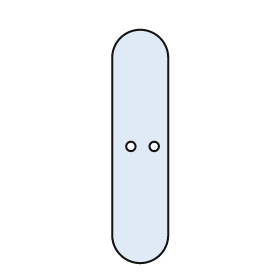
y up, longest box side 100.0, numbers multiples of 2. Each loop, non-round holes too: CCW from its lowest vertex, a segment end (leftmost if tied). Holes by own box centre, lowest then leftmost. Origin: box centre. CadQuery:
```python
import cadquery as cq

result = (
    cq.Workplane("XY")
    .moveTo(-12.0, -38.0)
    .threePointArc((0.0, -50.0), (12.0, -38.0))
    .lineTo(12.0, 38.0)
    .threePointArc((0.0, 50.0), (-12.0, 38.0))
    .close()
    .moveTo(-4.0, 0.0)
    .circle(2.0)
    .moveTo(6.0, 0.0)
    .circle(2.0)
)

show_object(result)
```